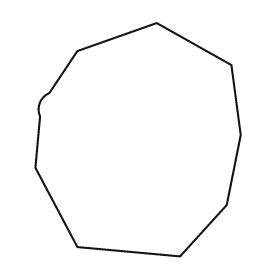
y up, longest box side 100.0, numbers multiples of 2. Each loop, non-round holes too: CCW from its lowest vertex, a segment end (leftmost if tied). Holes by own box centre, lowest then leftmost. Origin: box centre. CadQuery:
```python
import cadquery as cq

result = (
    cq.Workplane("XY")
    .moveTo(18.0, -50.0)
    .lineTo(38.0, -28.0)
    .lineTo(44.0, 2.0)
    .lineTo(40.0, 32.0)
    .lineTo(8.0, 50.0)
    .lineTo(-26.0, 38.0)
    .lineTo(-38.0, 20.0)
    .threePointArc((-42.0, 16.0), (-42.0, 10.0))
    .lineTo(-44.0, -12.0)
    .lineTo(-26.0, -46.0)
    .close()
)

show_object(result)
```